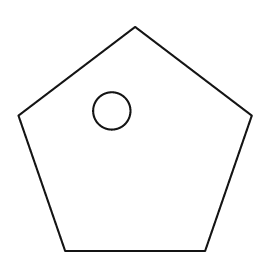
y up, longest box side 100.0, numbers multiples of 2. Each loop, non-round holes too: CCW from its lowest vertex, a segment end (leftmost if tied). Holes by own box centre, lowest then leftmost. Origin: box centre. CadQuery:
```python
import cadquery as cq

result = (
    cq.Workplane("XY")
    .moveTo(-30.0, -48.0)
    .lineTo(30.0, -48.0)
    .lineTo(50.0, 10.0)
    .lineTo(0.0, 48.0)
    .lineTo(-50.0, 10.0)
    .close()
    .moveTo(-10.0, 12.0)
    .circle(8.0)
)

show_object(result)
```